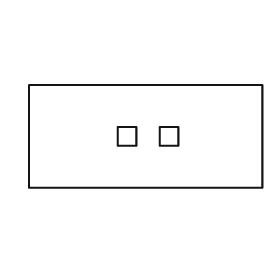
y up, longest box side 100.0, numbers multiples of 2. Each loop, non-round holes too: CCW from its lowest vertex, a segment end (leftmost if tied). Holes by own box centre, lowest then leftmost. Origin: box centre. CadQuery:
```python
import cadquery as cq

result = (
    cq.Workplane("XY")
    .moveTo(-50.0, -22.0)
    .lineTo(50.0, -22.0)
    .lineTo(50.0, 22.0)
    .lineTo(-50.0, 22.0)
    .close()
    .moveTo(-12.0, -4.0)
    .lineTo(-4.0, -4.0)
    .lineTo(-4.0, 4.0)
    .lineTo(-12.0, 4.0)
    .close()
    .moveTo(6.0, -4.0)
    .lineTo(14.0, -4.0)
    .lineTo(14.0, 4.0)
    .lineTo(6.0, 4.0)
    .close()
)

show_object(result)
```